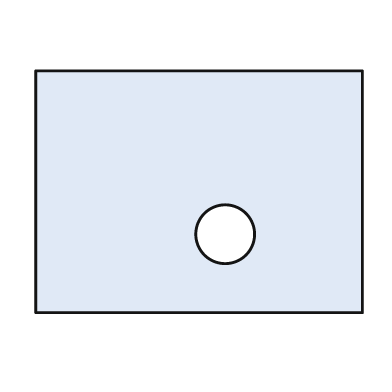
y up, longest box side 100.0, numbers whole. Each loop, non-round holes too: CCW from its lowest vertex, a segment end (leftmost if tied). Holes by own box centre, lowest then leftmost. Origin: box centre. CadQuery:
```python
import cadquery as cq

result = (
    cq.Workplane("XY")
    .moveTo(-50.0, -37.0)
    .lineTo(50.0, -37.0)
    .lineTo(50.0, 37.0)
    .lineTo(-50.0, 37.0)
    .close()
    .moveTo(8.0, -13.0)
    .circle(9.0)
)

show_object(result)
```